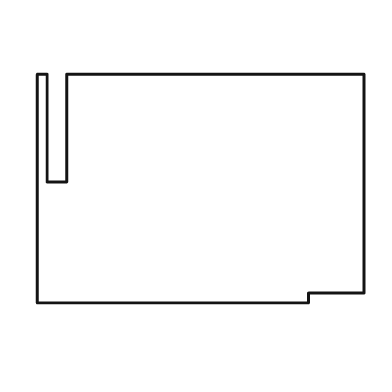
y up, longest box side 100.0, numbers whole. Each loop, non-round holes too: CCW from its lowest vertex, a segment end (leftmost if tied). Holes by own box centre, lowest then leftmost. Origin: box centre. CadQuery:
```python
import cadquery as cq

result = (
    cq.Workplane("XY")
    .moveTo(-50.0, -35.0)
    .lineTo(33.0, -35.0)
    .lineTo(33.0, -32.0)
    .lineTo(50.0, -32.0)
    .lineTo(50.0, 35.0)
    .lineTo(-41.0, 35.0)
    .lineTo(-41.0, 2.0)
    .lineTo(-47.0, 2.0)
    .lineTo(-47.0, 35.0)
    .lineTo(-50.0, 35.0)
    .close()
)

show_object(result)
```